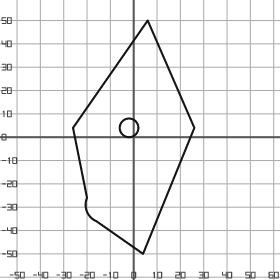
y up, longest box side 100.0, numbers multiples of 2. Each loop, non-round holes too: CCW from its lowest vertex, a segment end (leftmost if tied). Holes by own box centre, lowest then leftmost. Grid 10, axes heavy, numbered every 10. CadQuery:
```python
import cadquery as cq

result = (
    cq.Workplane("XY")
    .moveTo(4.0, -50.0)
    .lineTo(26.0, 4.0)
    .lineTo(6.0, 50.0)
    .lineTo(-26.0, 4.0)
    .lineTo(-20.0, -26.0)
    .threePointArc((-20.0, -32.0), (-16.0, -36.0))
    .close()
    .moveTo(-2.0, 4.0)
    .circle(4.0)
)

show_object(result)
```